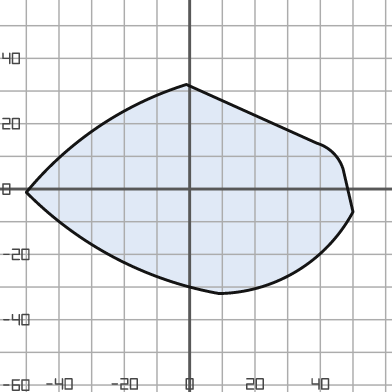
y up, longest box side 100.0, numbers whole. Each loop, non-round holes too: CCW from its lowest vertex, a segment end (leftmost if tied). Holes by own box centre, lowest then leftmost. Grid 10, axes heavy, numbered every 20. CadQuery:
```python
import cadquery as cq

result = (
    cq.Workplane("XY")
    .moveTo(9.0, -32.0)
    .threePointArc((33.0, -25.0), (50.0, -7.0))
    .lineTo(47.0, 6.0)
    .threePointArc((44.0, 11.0), (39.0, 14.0))
    .lineTo(-1.0, 32.0)
    .threePointArc((-28.0, 19.0), (-50.0, -1.0))
    .threePointArc((-23.0, -21.0), (9.0, -32.0))
    .close()
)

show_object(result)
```